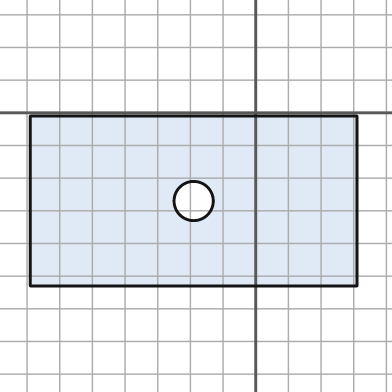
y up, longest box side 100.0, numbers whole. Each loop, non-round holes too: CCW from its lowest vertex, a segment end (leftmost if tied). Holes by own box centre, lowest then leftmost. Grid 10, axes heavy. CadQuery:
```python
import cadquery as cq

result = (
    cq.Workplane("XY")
    .moveTo(-69.0, -53.0)
    .lineTo(31.0, -53.0)
    .lineTo(31.0, -1.0)
    .lineTo(-69.0, -1.0)
    .close()
    .moveTo(-19.0, -27.0)
    .circle(6.0)
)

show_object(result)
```